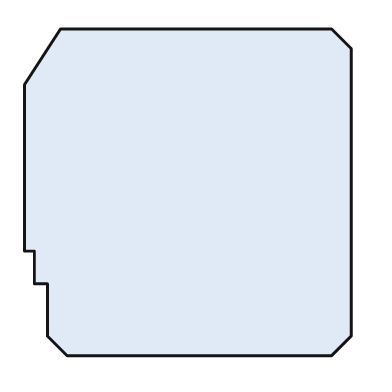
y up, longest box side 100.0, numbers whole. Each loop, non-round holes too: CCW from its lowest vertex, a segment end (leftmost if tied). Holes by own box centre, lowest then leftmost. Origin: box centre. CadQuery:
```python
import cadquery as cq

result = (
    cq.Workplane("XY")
    .moveTo(-37.0, -50.0)
    .lineTo(44.0, -50.0)
    .lineTo(50.0, -44.0)
    .lineTo(50.0, 44.0)
    .lineTo(44.0, 50.0)
    .lineTo(-39.0, 50.0)
    .lineTo(-50.0, 33.0)
    .lineTo(-50.0, -18.0)
    .lineTo(-47.0, -18.0)
    .lineTo(-47.0, -28.0)
    .lineTo(-43.0, -28.0)
    .lineTo(-43.0, -44.0)
    .close()
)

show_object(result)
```